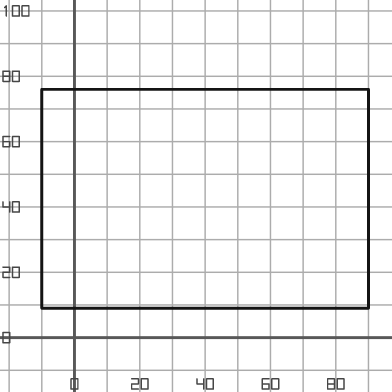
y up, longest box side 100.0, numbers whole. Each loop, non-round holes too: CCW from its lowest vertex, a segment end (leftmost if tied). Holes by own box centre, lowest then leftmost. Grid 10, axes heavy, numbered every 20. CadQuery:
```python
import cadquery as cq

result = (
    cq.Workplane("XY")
    .moveTo(-10.0, 9.0)
    .lineTo(90.0, 9.0)
    .lineTo(90.0, 76.0)
    .lineTo(-10.0, 76.0)
    .close()
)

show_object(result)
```